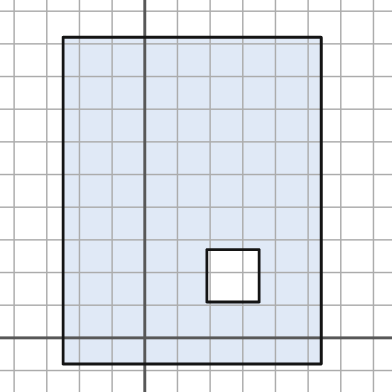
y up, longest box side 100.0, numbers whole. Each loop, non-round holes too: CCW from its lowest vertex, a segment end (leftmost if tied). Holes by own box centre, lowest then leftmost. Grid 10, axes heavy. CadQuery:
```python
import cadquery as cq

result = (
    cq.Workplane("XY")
    .moveTo(-25.0, -8.0)
    .lineTo(54.0, -8.0)
    .lineTo(54.0, 92.0)
    .lineTo(-25.0, 92.0)
    .close()
    .moveTo(19.0, 11.0)
    .lineTo(35.0, 11.0)
    .lineTo(35.0, 27.0)
    .lineTo(19.0, 27.0)
    .close()
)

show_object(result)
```